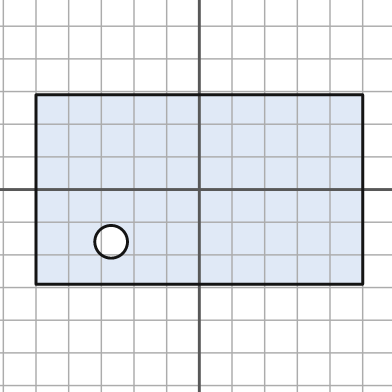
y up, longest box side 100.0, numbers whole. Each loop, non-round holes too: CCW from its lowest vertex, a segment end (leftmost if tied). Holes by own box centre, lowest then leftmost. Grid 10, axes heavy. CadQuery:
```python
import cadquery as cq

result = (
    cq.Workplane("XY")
    .moveTo(-50.0, -29.0)
    .lineTo(50.0, -29.0)
    .lineTo(50.0, 29.0)
    .lineTo(-50.0, 29.0)
    .close()
    .moveTo(-27.0, -16.0)
    .circle(5.0)
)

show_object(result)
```